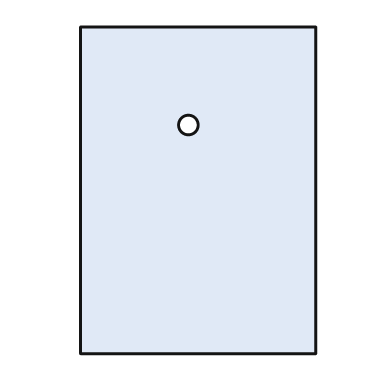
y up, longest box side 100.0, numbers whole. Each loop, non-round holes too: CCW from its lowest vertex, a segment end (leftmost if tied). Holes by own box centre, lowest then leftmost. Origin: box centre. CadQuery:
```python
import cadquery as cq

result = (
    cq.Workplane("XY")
    .moveTo(-36.0, -50.0)
    .lineTo(36.0, -50.0)
    .lineTo(36.0, 50.0)
    .lineTo(-36.0, 50.0)
    .close()
    .moveTo(-3.0, 20.0)
    .circle(3.0)
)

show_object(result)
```